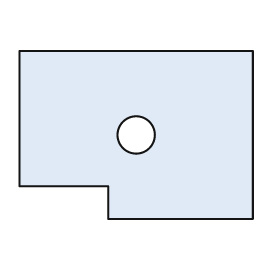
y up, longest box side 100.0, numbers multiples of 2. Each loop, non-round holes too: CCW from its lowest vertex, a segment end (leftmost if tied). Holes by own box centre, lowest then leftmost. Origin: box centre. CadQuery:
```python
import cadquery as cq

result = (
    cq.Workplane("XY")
    .moveTo(-12.0, -36.0)
    .lineTo(50.0, -36.0)
    .lineTo(50.0, 36.0)
    .lineTo(-50.0, 36.0)
    .lineTo(-50.0, -22.0)
    .lineTo(-12.0, -22.0)
    .close()
    .moveTo(0.0, 0.0)
    .circle(8.0)
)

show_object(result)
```